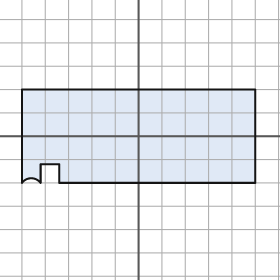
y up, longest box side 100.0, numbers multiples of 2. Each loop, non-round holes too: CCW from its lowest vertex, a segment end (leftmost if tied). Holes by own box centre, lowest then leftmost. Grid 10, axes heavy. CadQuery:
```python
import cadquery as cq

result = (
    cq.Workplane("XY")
    .moveTo(-50.0, -20.0)
    .threePointArc((-46.0, -18.0), (-42.0, -20.0))
    .lineTo(-42.0, -12.0)
    .lineTo(-34.0, -12.0)
    .lineTo(-34.0, -20.0)
    .lineTo(50.0, -20.0)
    .lineTo(50.0, 20.0)
    .lineTo(-50.0, 20.0)
    .close()
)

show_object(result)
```